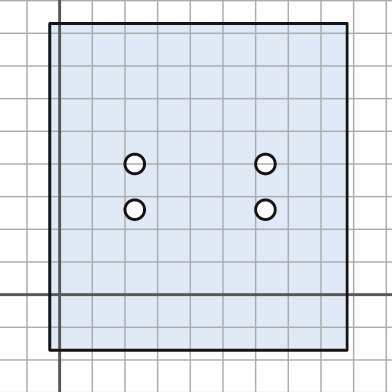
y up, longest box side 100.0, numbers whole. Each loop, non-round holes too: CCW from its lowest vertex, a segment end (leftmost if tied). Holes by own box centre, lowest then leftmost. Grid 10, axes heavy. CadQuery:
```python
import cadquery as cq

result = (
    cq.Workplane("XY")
    .moveTo(-3.0, -17.0)
    .lineTo(88.0, -17.0)
    .lineTo(88.0, 83.0)
    .lineTo(-3.0, 83.0)
    .close()
    .moveTo(23.0, 26.0)
    .circle(3.0)
    .moveTo(63.0, 26.0)
    .circle(3.0)
    .moveTo(23.0, 40.0)
    .circle(3.0)
    .moveTo(63.0, 40.0)
    .circle(3.0)
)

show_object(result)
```